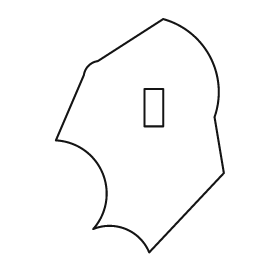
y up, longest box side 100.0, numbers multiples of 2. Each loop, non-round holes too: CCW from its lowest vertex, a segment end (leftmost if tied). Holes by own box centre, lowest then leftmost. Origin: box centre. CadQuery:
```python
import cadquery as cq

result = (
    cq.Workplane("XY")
    .moveTo(4.0, -50.0)
    .lineTo(36.0, -16.0)
    .lineTo(32.0, 8.0)
    .threePointArc((30.0, 34.0), (10.0, 50.0))
    .lineTo(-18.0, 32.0)
    .threePointArc((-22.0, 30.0), (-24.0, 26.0))
    .lineTo(-36.0, -2.0)
    .threePointArc((-16.0, -16.0), (-20.0, -40.0))
    .threePointArc((-6.0, -40.0), (4.0, -50.0))
    .close()
    .moveTo(2.0, 4.0)
    .lineTo(10.0, 4.0)
    .lineTo(10.0, 20.0)
    .lineTo(2.0, 20.0)
    .close()
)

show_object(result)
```